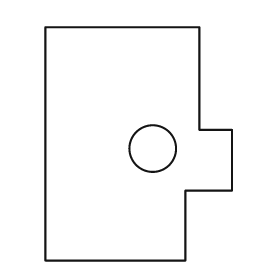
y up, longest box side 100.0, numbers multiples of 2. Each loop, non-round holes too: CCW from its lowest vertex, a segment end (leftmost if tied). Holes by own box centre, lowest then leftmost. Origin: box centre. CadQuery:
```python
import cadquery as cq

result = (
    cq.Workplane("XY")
    .moveTo(-40.0, -50.0)
    .lineTo(20.0, -50.0)
    .lineTo(20.0, -20.0)
    .lineTo(40.0, -20.0)
    .lineTo(40.0, 6.0)
    .lineTo(26.0, 6.0)
    .lineTo(26.0, 50.0)
    .lineTo(-40.0, 50.0)
    .close()
    .moveTo(6.0, -2.0)
    .circle(10.0)
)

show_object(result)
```